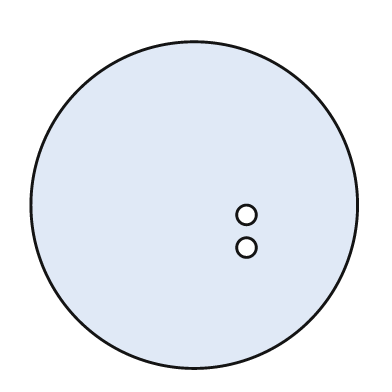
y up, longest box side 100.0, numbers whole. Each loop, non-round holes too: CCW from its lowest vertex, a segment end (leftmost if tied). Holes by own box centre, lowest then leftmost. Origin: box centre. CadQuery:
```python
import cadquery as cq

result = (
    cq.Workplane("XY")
    .moveTo(0.0, 0.0)
    .circle(50.0)
    .moveTo(16.0, -13.0)
    .circle(3.0)
    .moveTo(16.0, -3.0)
    .circle(3.0)
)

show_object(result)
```